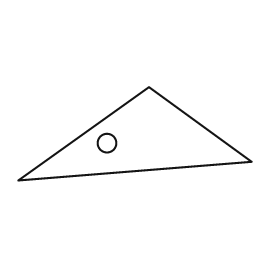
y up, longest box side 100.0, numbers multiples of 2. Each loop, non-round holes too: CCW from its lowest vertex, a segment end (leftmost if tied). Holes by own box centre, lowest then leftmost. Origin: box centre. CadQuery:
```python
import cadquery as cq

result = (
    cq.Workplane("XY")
    .moveTo(-50.0, -20.0)
    .lineTo(50.0, -12.0)
    .lineTo(6.0, 20.0)
    .close()
    .moveTo(-12.0, -4.0)
    .circle(4.0)
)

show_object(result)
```